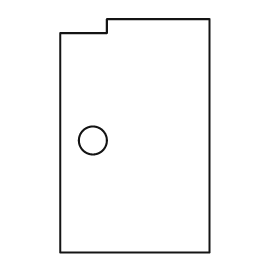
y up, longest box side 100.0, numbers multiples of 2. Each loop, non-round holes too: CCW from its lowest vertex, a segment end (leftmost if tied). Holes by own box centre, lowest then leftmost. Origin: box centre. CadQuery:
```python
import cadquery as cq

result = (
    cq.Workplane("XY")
    .moveTo(-32.0, -50.0)
    .lineTo(32.0, -50.0)
    .lineTo(32.0, 50.0)
    .lineTo(-12.0, 50.0)
    .lineTo(-12.0, 44.0)
    .lineTo(-32.0, 44.0)
    .close()
    .moveTo(-18.0, -2.0)
    .circle(6.0)
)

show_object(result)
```